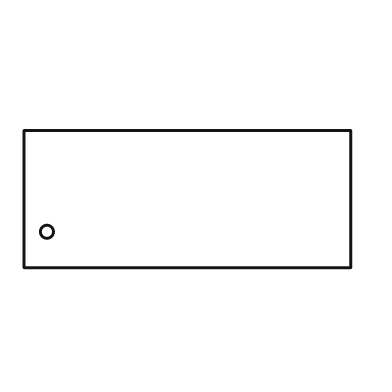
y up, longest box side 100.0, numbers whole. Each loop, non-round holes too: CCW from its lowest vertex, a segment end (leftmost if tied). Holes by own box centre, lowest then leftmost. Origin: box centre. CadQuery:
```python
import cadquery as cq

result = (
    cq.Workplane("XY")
    .moveTo(-50.0, -21.0)
    .lineTo(50.0, -21.0)
    .lineTo(50.0, 21.0)
    .lineTo(-50.0, 21.0)
    .close()
    .moveTo(-43.0, -10.0)
    .circle(2.0)
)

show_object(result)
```